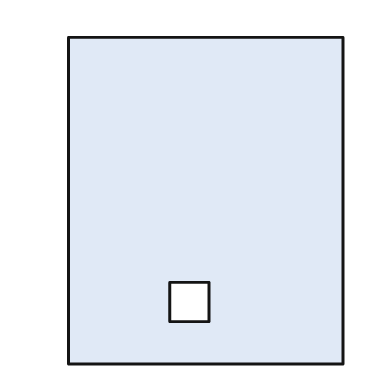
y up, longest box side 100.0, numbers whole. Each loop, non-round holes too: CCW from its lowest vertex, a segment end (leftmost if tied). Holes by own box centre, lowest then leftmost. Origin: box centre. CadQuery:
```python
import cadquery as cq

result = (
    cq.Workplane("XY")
    .moveTo(-42.0, -50.0)
    .lineTo(42.0, -50.0)
    .lineTo(42.0, 50.0)
    .lineTo(-42.0, 50.0)
    .close()
    .moveTo(-11.0, -37.0)
    .lineTo(1.0, -37.0)
    .lineTo(1.0, -25.0)
    .lineTo(-11.0, -25.0)
    .close()
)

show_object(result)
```